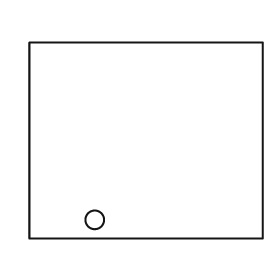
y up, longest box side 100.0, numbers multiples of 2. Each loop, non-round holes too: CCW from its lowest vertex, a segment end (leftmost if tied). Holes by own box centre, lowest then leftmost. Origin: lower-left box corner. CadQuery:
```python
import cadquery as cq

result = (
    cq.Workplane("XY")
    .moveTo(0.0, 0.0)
    .lineTo(100.0, 0.0)
    .lineTo(100.0, 84.0)
    .lineTo(0.0, 84.0)
    .close()
    .moveTo(28.0, 8.0)
    .circle(4.0)
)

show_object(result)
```